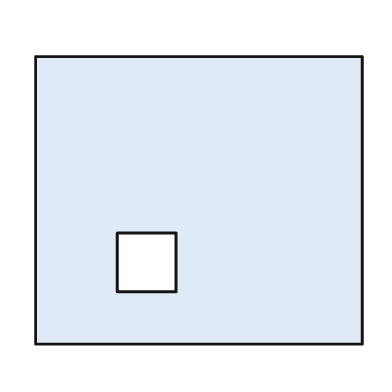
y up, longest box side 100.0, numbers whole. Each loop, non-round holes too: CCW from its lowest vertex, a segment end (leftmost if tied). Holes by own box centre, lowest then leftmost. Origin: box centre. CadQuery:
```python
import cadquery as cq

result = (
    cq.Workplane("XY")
    .moveTo(-50.0, -44.0)
    .lineTo(50.0, -44.0)
    .lineTo(50.0, 44.0)
    .lineTo(-50.0, 44.0)
    .close()
    .moveTo(-25.0, -28.0)
    .lineTo(-7.0, -28.0)
    .lineTo(-7.0, -10.0)
    .lineTo(-25.0, -10.0)
    .close()
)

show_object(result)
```